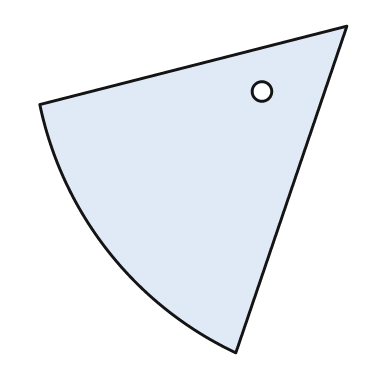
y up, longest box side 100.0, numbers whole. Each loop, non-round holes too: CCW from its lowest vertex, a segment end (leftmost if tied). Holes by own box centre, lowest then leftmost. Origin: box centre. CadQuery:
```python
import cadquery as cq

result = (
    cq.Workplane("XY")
    .moveTo(13.0, -50.0)
    .lineTo(47.0, 50.0)
    .lineTo(-47.0, 26.0)
    .threePointArc((-26.0, -19.0), (13.0, -50.0))
    .close()
    .moveTo(21.0, 30.0)
    .circle(3.0)
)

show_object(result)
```